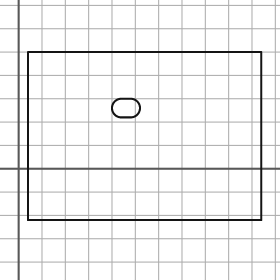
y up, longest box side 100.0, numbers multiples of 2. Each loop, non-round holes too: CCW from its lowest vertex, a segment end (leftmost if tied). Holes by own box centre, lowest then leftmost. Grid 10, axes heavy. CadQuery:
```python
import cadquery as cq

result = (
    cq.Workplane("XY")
    .moveTo(4.0, -22.0)
    .lineTo(104.0, -22.0)
    .lineTo(104.0, 50.0)
    .lineTo(4.0, 50.0)
    .close()
    .moveTo(44.0, 22.0)
    .lineTo(48.0, 22.0)
    .threePointArc((52.0, 26.0), (48.0, 30.0))
    .lineTo(44.0, 30.0)
    .threePointArc((40.0, 26.0), (44.0, 22.0))
    .close()
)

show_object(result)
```